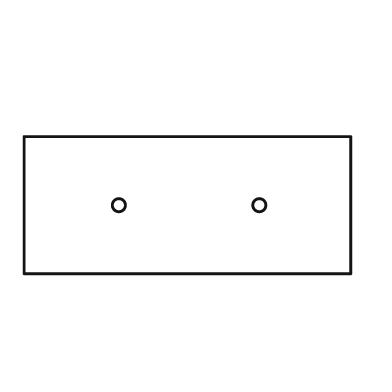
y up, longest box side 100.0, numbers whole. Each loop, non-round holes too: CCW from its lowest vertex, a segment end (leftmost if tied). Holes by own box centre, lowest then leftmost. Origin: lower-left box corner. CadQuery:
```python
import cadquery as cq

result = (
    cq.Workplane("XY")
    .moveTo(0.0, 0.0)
    .lineTo(100.0, 0.0)
    .lineTo(100.0, 42.0)
    .lineTo(0.0, 42.0)
    .close()
    .moveTo(29.0, 21.0)
    .circle(2.0)
    .moveTo(72.0, 21.0)
    .circle(2.0)
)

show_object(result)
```